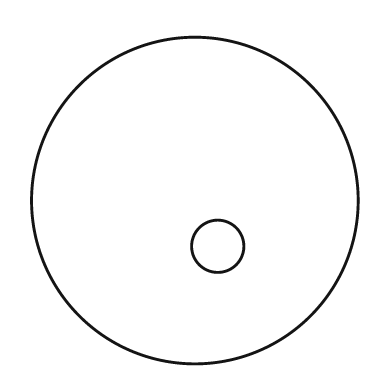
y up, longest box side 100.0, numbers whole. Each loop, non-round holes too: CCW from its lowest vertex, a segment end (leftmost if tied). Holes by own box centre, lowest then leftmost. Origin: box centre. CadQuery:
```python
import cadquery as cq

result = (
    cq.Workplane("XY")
    .moveTo(0.0, 0.0)
    .circle(50.0)
    .moveTo(7.0, -14.0)
    .circle(8.0)
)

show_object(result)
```